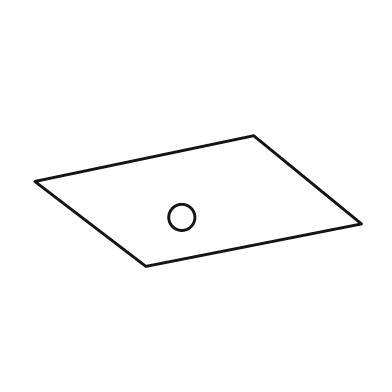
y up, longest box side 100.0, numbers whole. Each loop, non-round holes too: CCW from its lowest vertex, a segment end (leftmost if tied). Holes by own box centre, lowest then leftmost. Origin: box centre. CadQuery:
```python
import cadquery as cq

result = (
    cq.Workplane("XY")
    .moveTo(-16.0, -20.0)
    .lineTo(50.0, -7.0)
    .lineTo(17.0, 20.0)
    .lineTo(-50.0, 6.0)
    .close()
    .moveTo(-5.0, -5.0)
    .circle(4.0)
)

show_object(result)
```